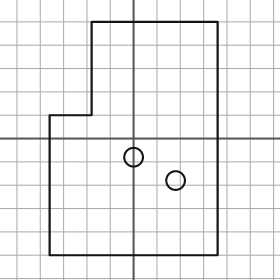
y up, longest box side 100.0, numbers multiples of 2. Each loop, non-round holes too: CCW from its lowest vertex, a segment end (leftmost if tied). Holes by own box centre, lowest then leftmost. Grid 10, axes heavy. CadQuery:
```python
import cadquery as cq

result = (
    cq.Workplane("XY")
    .moveTo(-36.0, -50.0)
    .lineTo(36.0, -50.0)
    .lineTo(36.0, 50.0)
    .lineTo(-18.0, 50.0)
    .lineTo(-18.0, 10.0)
    .lineTo(-36.0, 10.0)
    .close()
    .moveTo(18.0, -18.0)
    .circle(4.0)
    .moveTo(0.0, -8.0)
    .circle(4.0)
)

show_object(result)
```